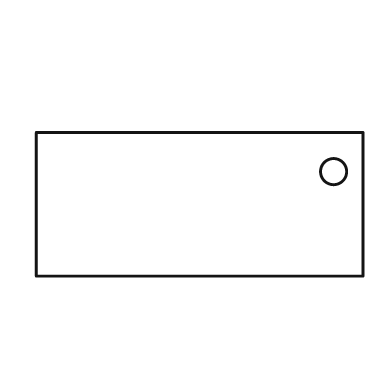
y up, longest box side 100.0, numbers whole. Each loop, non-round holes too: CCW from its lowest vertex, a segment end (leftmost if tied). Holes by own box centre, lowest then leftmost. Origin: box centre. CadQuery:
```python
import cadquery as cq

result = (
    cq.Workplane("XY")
    .moveTo(-50.0, -22.0)
    .lineTo(50.0, -22.0)
    .lineTo(50.0, 22.0)
    .lineTo(-50.0, 22.0)
    .close()
    .moveTo(41.0, 10.0)
    .circle(4.0)
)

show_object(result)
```